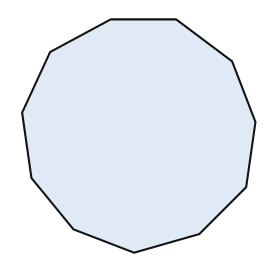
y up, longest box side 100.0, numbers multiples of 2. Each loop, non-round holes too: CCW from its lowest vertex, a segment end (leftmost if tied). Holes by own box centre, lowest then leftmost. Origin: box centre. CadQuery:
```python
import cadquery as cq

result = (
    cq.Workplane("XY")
    .moveTo(-2.0, -50.0)
    .lineTo(26.0, -42.0)
    .lineTo(46.0, -22.0)
    .lineTo(50.0, 6.0)
    .lineTo(40.0, 32.0)
    .lineTo(16.0, 50.0)
    .lineTo(-12.0, 50.0)
    .lineTo(-38.0, 36.0)
    .lineTo(-50.0, 10.0)
    .lineTo(-46.0, -18.0)
    .lineTo(-28.0, -40.0)
    .close()
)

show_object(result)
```